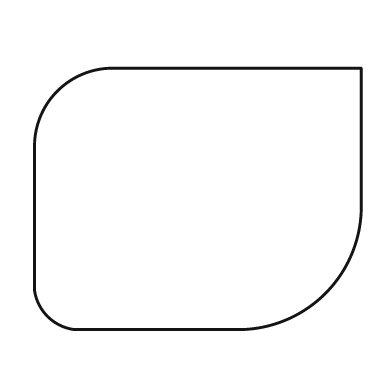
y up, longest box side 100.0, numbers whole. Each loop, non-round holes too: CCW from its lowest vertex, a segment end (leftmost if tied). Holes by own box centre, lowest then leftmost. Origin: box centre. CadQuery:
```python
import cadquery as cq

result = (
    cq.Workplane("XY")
    .moveTo(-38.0, -40.0)
    .lineTo(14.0, -40.0)
    .threePointArc((39.0, -29.0), (50.0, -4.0))
    .lineTo(50.0, 40.0)
    .lineTo(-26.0, 40.0)
    .threePointArc((-43.0, 33.0), (-50.0, 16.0))
    .lineTo(-50.0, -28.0)
    .threePointArc((-46.0, -36.0), (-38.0, -40.0))
    .close()
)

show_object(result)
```